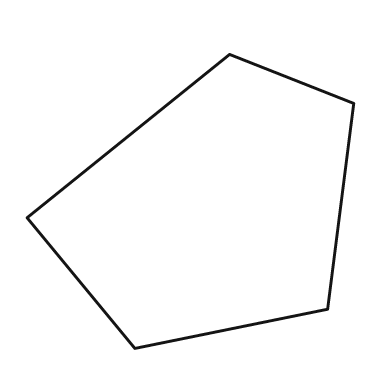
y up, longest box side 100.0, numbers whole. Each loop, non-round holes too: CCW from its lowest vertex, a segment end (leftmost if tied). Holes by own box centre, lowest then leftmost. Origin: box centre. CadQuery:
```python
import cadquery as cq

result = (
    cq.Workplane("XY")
    .moveTo(-17.0, -45.0)
    .lineTo(42.0, -33.0)
    .lineTo(50.0, 30.0)
    .lineTo(12.0, 45.0)
    .lineTo(-50.0, -5.0)
    .close()
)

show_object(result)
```